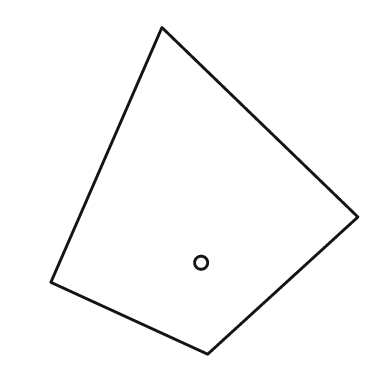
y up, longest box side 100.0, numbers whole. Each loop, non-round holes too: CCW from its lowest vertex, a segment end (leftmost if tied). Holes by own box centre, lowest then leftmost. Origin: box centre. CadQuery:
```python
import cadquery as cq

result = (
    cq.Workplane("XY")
    .moveTo(1.0, -50.0)
    .lineTo(47.0, -8.0)
    .lineTo(-13.0, 50.0)
    .lineTo(-47.0, -28.0)
    .close()
    .moveTo(-1.0, -22.0)
    .circle(2.0)
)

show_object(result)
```